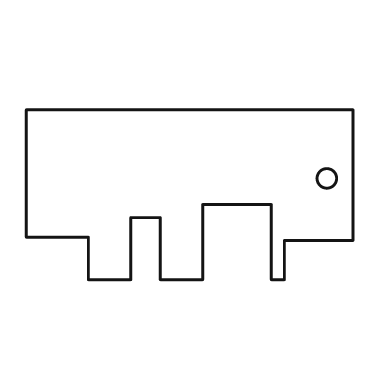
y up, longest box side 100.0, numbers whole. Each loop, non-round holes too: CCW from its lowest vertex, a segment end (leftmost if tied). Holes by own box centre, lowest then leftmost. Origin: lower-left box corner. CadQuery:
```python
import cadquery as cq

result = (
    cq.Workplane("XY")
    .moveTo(19.0, 0.0)
    .lineTo(32.0, 0.0)
    .lineTo(32.0, 19.0)
    .lineTo(41.0, 19.0)
    .lineTo(41.0, 0.0)
    .lineTo(54.0, 0.0)
    .lineTo(54.0, 23.0)
    .lineTo(75.0, 23.0)
    .lineTo(75.0, 0.0)
    .lineTo(79.0, 0.0)
    .lineTo(79.0, 12.0)
    .lineTo(100.0, 12.0)
    .lineTo(100.0, 52.0)
    .lineTo(0.0, 52.0)
    .lineTo(0.0, 13.0)
    .lineTo(19.0, 13.0)
    .close()
    .moveTo(92.0, 31.0)
    .circle(3.0)
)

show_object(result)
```